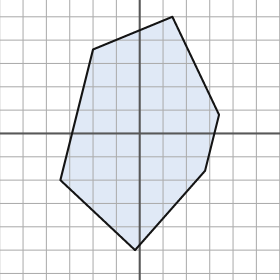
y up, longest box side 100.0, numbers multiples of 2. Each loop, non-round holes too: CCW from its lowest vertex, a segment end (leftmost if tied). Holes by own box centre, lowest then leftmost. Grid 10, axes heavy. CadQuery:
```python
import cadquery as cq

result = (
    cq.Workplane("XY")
    .moveTo(-2.0, -50.0)
    .lineTo(28.0, -16.0)
    .lineTo(34.0, 8.0)
    .lineTo(14.0, 50.0)
    .lineTo(-20.0, 36.0)
    .lineTo(-34.0, -20.0)
    .close()
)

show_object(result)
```